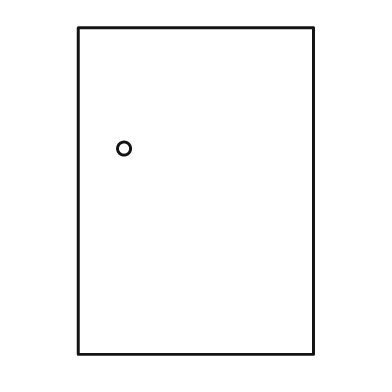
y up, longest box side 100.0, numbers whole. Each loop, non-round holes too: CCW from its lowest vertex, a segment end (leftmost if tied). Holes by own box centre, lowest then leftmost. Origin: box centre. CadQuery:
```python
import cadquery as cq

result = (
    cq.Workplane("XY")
    .moveTo(-36.0, -50.0)
    .lineTo(36.0, -50.0)
    .lineTo(36.0, 50.0)
    .lineTo(-36.0, 50.0)
    .close()
    .moveTo(-22.0, 13.0)
    .circle(2.0)
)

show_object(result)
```